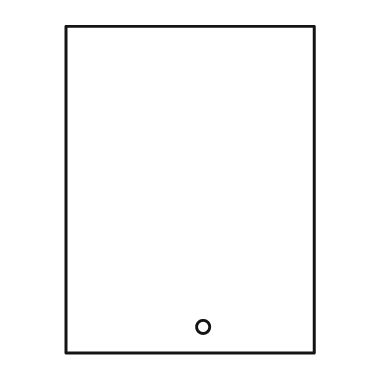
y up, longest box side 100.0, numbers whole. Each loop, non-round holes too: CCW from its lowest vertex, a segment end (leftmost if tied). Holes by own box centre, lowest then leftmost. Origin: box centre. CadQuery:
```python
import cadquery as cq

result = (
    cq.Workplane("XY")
    .moveTo(-38.0, -50.0)
    .lineTo(38.0, -50.0)
    .lineTo(38.0, 50.0)
    .lineTo(-38.0, 50.0)
    .close()
    .moveTo(4.0, -42.0)
    .circle(2.0)
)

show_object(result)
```